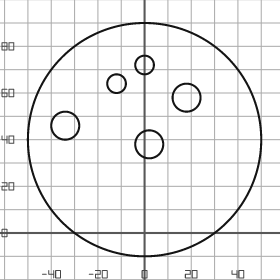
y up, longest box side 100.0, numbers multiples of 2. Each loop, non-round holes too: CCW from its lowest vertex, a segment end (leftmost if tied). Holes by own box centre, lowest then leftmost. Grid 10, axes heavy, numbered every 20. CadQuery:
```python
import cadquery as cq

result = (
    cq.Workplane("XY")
    .moveTo(0.0, 40.0)
    .circle(50.0)
    .moveTo(2.0, 38.0)
    .circle(6.0)
    .moveTo(-34.0, 46.0)
    .circle(6.0)
    .moveTo(18.0, 58.0)
    .circle(6.0)
    .moveTo(-12.0, 64.0)
    .circle(4.0)
    .moveTo(0.0, 72.0)
    .circle(4.0)
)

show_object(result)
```